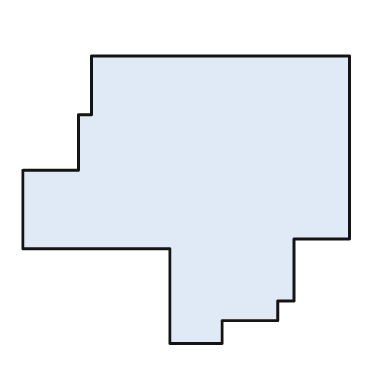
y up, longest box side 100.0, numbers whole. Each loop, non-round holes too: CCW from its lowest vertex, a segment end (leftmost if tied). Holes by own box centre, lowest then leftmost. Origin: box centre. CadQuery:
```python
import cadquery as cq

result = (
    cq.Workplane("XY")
    .moveTo(-5.0, -44.0)
    .lineTo(11.0, -44.0)
    .lineTo(11.0, -37.0)
    .lineTo(28.0, -37.0)
    .lineTo(28.0, -31.0)
    .lineTo(33.0, -31.0)
    .lineTo(33.0, -12.0)
    .lineTo(50.0, -12.0)
    .lineTo(50.0, 44.0)
    .lineTo(-29.0, 44.0)
    .lineTo(-29.0, 26.0)
    .lineTo(-33.0, 26.0)
    .lineTo(-33.0, 9.0)
    .lineTo(-50.0, 9.0)
    .lineTo(-50.0, -15.0)
    .lineTo(-5.0, -15.0)
    .close()
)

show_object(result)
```